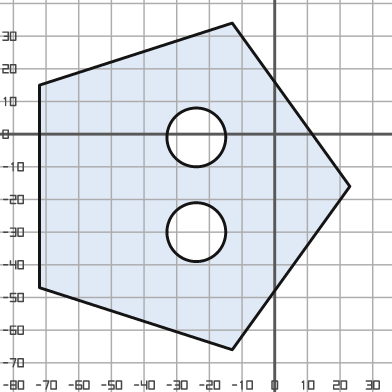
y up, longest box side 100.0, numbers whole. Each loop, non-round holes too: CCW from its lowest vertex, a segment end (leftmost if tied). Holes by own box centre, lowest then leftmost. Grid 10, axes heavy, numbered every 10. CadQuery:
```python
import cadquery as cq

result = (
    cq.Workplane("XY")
    .moveTo(-13.0, -66.0)
    .lineTo(23.0, -16.0)
    .lineTo(-13.0, 34.0)
    .lineTo(-72.0, 15.0)
    .lineTo(-72.0, -47.0)
    .close()
    .moveTo(-24.0, -30.0)
    .circle(9.0)
    .moveTo(-24.0, -1.0)
    .circle(9.0)
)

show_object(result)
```